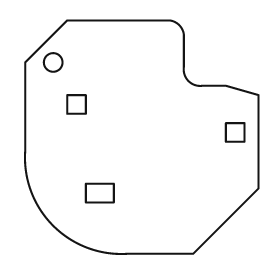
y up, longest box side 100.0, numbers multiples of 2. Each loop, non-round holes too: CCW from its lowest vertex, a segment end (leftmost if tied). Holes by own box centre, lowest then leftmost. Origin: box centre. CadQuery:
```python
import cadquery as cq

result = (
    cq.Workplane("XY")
    .moveTo(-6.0, -50.0)
    .lineTo(22.0, -50.0)
    .lineTo(50.0, -22.0)
    .lineTo(50.0, 18.0)
    .lineTo(36.0, 22.0)
    .lineTo(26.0, 22.0)
    .threePointArc((20.0, 24.0), (18.0, 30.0))
    .lineTo(18.0, 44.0)
    .threePointArc((16.0, 48.0), (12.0, 50.0))
    .lineTo(-32.0, 50.0)
    .lineTo(-50.0, 32.0)
    .lineTo(-50.0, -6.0)
    .threePointArc((-38.0, -38.0), (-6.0, -50.0))
    .close()
    .moveTo(-24.0, -28.0)
    .lineTo(-12.0, -28.0)
    .lineTo(-12.0, -20.0)
    .lineTo(-24.0, -20.0)
    .close()
    .moveTo(36.0, -2.0)
    .lineTo(44.0, -2.0)
    .lineTo(44.0, 6.0)
    .lineTo(36.0, 6.0)
    .close()
    .moveTo(-32.0, 10.0)
    .lineTo(-24.0, 10.0)
    .lineTo(-24.0, 18.0)
    .lineTo(-32.0, 18.0)
    .close()
    .moveTo(-38.0, 32.0)
    .circle(4.0)
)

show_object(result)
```